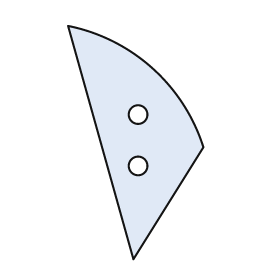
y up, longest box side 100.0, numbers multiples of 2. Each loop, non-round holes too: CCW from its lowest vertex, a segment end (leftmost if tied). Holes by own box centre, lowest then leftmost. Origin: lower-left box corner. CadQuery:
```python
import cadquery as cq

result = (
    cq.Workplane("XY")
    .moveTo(28.0, 0.0)
    .lineTo(58.0, 48.0)
    .threePointArc((36.0, 82.0), (0.0, 100.0))
    .close()
    .moveTo(30.0, 40.0)
    .circle(4.0)
    .moveTo(30.0, 62.0)
    .circle(4.0)
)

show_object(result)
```